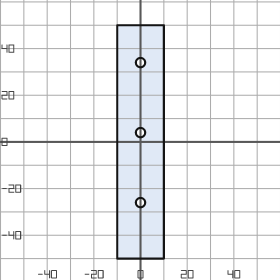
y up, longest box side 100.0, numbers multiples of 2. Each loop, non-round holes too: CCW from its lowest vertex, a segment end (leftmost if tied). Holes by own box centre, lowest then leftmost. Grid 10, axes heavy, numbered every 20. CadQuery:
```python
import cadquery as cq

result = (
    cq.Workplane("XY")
    .moveTo(-10.0, -50.0)
    .lineTo(10.0, -50.0)
    .lineTo(10.0, 50.0)
    .lineTo(-10.0, 50.0)
    .close()
    .moveTo(0.0, -26.0)
    .circle(2.0)
    .moveTo(0.0, 4.0)
    .circle(2.0)
    .moveTo(0.0, 34.0)
    .circle(2.0)
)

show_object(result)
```